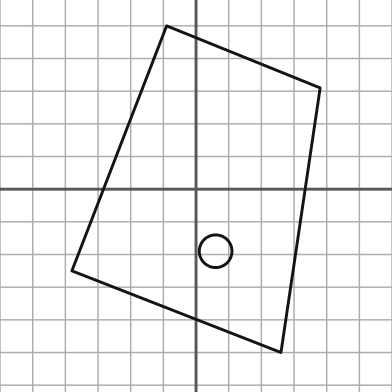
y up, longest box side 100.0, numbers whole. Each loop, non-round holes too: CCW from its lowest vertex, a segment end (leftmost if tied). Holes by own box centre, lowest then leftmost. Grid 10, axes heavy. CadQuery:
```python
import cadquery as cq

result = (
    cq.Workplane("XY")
    .moveTo(26.0, -50.0)
    .lineTo(38.0, 31.0)
    .lineTo(-9.0, 50.0)
    .lineTo(-38.0, -25.0)
    .close()
    .moveTo(6.0, -19.0)
    .circle(5.0)
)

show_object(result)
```